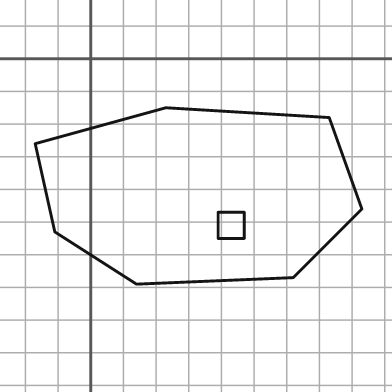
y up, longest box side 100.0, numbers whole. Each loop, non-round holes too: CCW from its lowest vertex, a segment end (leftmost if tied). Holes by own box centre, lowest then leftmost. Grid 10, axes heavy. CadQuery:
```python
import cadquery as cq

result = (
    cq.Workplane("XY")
    .moveTo(14.0, -69.0)
    .lineTo(62.0, -67.0)
    .lineTo(83.0, -46.0)
    .lineTo(73.0, -18.0)
    .lineTo(23.0, -15.0)
    .lineTo(-17.0, -26.0)
    .lineTo(-11.0, -53.0)
    .close()
    .moveTo(39.0, -55.0)
    .lineTo(47.0, -55.0)
    .lineTo(47.0, -47.0)
    .lineTo(39.0, -47.0)
    .close()
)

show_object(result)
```